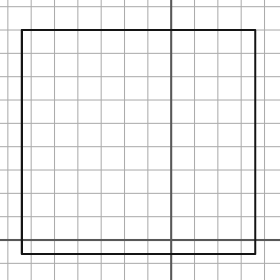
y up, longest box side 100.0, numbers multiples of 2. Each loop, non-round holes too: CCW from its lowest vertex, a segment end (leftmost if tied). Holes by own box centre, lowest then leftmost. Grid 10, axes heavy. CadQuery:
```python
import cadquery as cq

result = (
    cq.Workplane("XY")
    .moveTo(-64.0, -6.0)
    .lineTo(36.0, -6.0)
    .lineTo(36.0, 90.0)
    .lineTo(-64.0, 90.0)
    .close()
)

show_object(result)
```